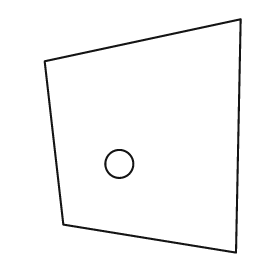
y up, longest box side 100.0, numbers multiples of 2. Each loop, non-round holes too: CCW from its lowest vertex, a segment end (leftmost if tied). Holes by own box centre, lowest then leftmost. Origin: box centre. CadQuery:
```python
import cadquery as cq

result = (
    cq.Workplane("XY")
    .moveTo(40.0, -50.0)
    .lineTo(42.0, 50.0)
    .lineTo(-42.0, 32.0)
    .lineTo(-34.0, -38.0)
    .close()
    .moveTo(-10.0, -12.0)
    .circle(6.0)
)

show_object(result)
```